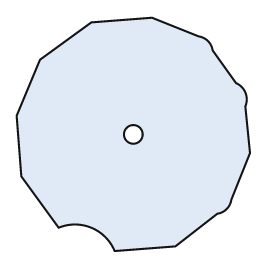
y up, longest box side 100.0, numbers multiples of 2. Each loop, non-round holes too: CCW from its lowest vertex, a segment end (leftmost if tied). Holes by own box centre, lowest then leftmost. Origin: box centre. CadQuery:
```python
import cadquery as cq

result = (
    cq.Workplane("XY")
    .moveTo(-8.0, -50.0)
    .lineTo(18.0, -48.0)
    .lineTo(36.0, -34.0)
    .threePointArc((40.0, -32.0), (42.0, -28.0))
    .lineTo(50.0, -8.0)
    .lineTo(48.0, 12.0)
    .threePointArc((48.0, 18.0), (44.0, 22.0))
    .lineTo(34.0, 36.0)
    .threePointArc((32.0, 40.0), (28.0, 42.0))
    .lineTo(8.0, 50.0)
    .lineTo(-18.0, 48.0)
    .lineTo(-40.0, 32.0)
    .lineTo(-50.0, 8.0)
    .lineTo(-48.0, -18.0)
    .lineTo(-32.0, -40.0)
    .threePointArc((-18.0, -40.0), (-8.0, -50.0))
    .close()
    .moveTo(0.0, 0.0)
    .circle(4.0)
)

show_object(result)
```